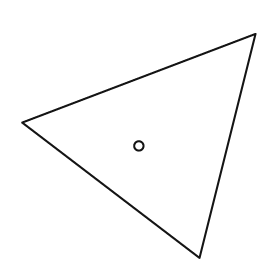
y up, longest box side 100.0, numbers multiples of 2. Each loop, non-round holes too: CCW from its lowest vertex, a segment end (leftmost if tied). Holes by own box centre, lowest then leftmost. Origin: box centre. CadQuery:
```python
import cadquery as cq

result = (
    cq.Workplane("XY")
    .moveTo(26.0, -48.0)
    .lineTo(50.0, 48.0)
    .lineTo(-50.0, 10.0)
    .close()
    .moveTo(0.0, 0.0)
    .circle(2.0)
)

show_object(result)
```